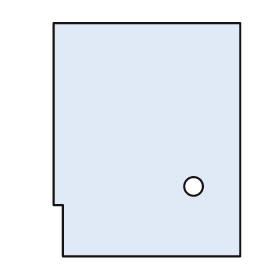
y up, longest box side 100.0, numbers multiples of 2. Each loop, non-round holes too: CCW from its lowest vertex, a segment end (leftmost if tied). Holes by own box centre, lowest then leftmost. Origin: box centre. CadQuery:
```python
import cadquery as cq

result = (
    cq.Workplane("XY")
    .moveTo(-36.0, -50.0)
    .lineTo(40.0, -50.0)
    .lineTo(40.0, 50.0)
    .lineTo(-40.0, 50.0)
    .lineTo(-40.0, -28.0)
    .lineTo(-36.0, -28.0)
    .close()
    .moveTo(20.0, -20.0)
    .circle(4.0)
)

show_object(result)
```